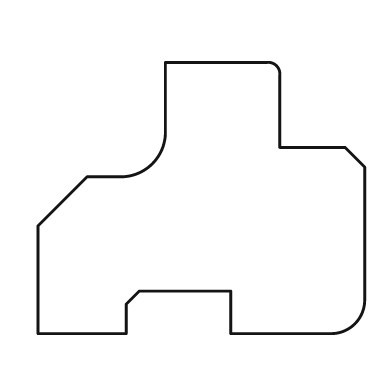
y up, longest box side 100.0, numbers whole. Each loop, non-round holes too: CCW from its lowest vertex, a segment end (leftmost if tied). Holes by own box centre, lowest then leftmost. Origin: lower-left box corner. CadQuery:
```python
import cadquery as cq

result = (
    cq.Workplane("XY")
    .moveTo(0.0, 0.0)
    .lineTo(27.0, 0.0)
    .lineTo(27.0, 9.0)
    .lineTo(31.0, 13.0)
    .lineTo(59.0, 13.0)
    .lineTo(59.0, 0.0)
    .lineTo(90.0, 0.0)
    .threePointArc((97.0, 3.0), (100.0, 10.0))
    .lineTo(100.0, 51.0)
    .lineTo(94.0, 57.0)
    .lineTo(74.0, 57.0)
    .lineTo(74.0, 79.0)
    .threePointArc((73.0, 82.0), (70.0, 83.0))
    .lineTo(39.0, 83.0)
    .lineTo(39.0, 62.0)
    .threePointArc((35.0, 52.0), (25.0, 48.0))
    .lineTo(15.0, 48.0)
    .lineTo(0.0, 33.0)
    .close()
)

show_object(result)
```